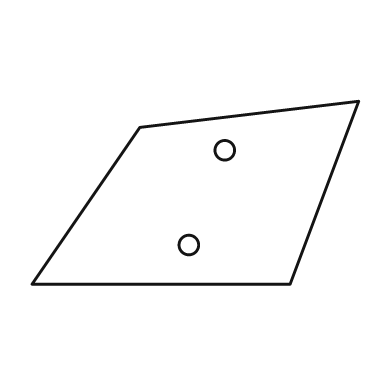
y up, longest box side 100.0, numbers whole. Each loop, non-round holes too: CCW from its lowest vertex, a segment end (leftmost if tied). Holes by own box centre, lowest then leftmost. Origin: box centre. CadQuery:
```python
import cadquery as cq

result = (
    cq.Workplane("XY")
    .moveTo(-50.0, -28.0)
    .lineTo(29.0, -28.0)
    .lineTo(50.0, 28.0)
    .lineTo(-17.0, 20.0)
    .close()
    .moveTo(-2.0, -16.0)
    .circle(3.0)
    .moveTo(9.0, 13.0)
    .circle(3.0)
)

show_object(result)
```